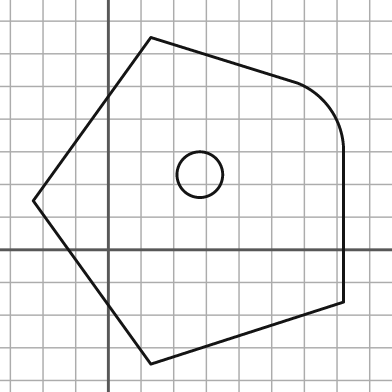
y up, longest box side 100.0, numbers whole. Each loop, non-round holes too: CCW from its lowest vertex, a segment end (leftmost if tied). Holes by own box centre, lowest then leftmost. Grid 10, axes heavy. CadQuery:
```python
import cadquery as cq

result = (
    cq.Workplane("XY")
    .moveTo(13.0, -35.0)
    .lineTo(72.0, -16.0)
    .lineTo(72.0, 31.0)
    .threePointArc((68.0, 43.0), (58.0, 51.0))
    .lineTo(13.0, 65.0)
    .lineTo(-23.0, 15.0)
    .close()
    .moveTo(28.0, 23.0)
    .circle(7.0)
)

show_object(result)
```